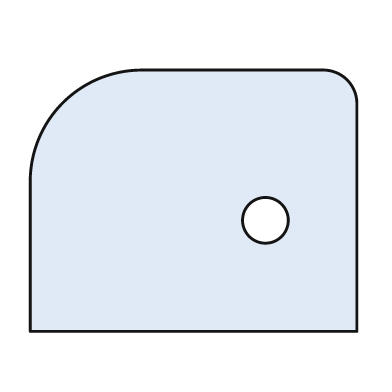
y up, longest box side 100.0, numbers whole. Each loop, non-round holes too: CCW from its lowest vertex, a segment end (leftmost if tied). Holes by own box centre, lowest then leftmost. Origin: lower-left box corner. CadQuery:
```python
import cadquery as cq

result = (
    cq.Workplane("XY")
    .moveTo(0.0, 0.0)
    .lineTo(100.0, 0.0)
    .lineTo(100.0, 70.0)
    .threePointArc((97.0, 77.0), (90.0, 80.0))
    .lineTo(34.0, 80.0)
    .threePointArc((10.0, 70.0), (0.0, 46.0))
    .close()
    .moveTo(72.0, 34.0)
    .circle(7.0)
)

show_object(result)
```